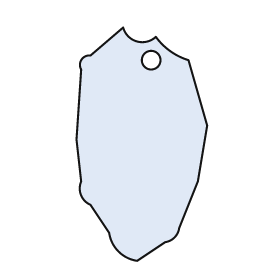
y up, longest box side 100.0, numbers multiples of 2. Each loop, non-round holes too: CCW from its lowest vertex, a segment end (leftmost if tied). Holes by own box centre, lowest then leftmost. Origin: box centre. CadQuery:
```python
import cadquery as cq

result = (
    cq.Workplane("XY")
    .moveTo(-2.0, -50.0)
    .lineTo(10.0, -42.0)
    .threePointArc((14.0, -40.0), (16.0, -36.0))
    .lineTo(24.0, -16.0)
    .lineTo(28.0, 8.0)
    .lineTo(20.0, 36.0)
    .threePointArc((12.0, 40.0), (6.0, 46.0))
    .threePointArc((-2.0, 44.0), (-8.0, 50.0))
    .lineTo(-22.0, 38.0)
    .threePointArc((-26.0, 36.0), (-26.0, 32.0))
    .lineTo(-28.0, 2.0)
    .lineTo(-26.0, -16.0)
    .threePointArc((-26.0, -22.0), (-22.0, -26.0))
    .lineTo(-14.0, -38.0)
    .threePointArc((-10.0, -46.0), (-2.0, -50.0))
    .close()
    .moveTo(4.0, 36.0)
    .circle(4.0)
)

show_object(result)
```